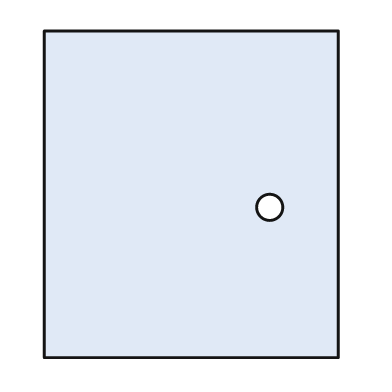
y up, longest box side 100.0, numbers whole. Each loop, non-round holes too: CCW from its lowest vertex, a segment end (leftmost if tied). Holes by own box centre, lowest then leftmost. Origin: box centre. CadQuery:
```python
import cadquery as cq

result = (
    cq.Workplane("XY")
    .moveTo(-45.0, -50.0)
    .lineTo(45.0, -50.0)
    .lineTo(45.0, 50.0)
    .lineTo(-45.0, 50.0)
    .close()
    .moveTo(24.0, -4.0)
    .circle(4.0)
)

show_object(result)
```